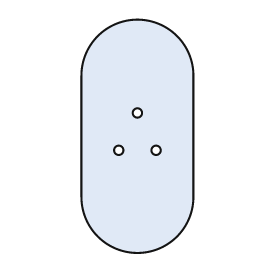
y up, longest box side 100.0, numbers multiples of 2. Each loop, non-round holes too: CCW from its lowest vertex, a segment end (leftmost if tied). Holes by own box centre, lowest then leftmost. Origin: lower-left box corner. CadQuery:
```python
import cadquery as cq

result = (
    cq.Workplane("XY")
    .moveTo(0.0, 24.0)
    .threePointArc((24.0, 0.0), (48.0, 24.0))
    .lineTo(48.0, 76.0)
    .threePointArc((24.0, 100.0), (0.0, 76.0))
    .close()
    .moveTo(16.0, 44.0)
    .circle(2.0)
    .moveTo(32.0, 44.0)
    .circle(2.0)
    .moveTo(24.0, 60.0)
    .circle(2.0)
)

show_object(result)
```